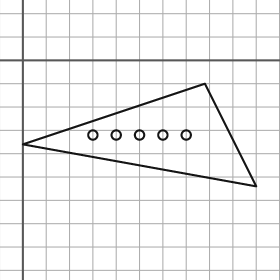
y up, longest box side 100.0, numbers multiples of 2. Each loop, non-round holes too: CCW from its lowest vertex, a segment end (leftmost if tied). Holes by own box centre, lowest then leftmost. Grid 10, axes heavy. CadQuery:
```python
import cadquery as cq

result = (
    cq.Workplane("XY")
    .moveTo(100.0, -54.0)
    .lineTo(78.0, -10.0)
    .lineTo(0.0, -36.0)
    .close()
    .moveTo(30.0, -32.0)
    .circle(2.0)
    .moveTo(40.0, -32.0)
    .circle(2.0)
    .moveTo(50.0, -32.0)
    .circle(2.0)
    .moveTo(60.0, -32.0)
    .circle(2.0)
    .moveTo(70.0, -32.0)
    .circle(2.0)
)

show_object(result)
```